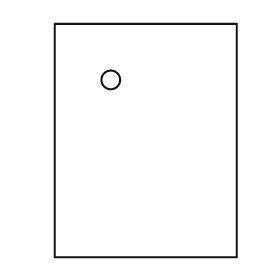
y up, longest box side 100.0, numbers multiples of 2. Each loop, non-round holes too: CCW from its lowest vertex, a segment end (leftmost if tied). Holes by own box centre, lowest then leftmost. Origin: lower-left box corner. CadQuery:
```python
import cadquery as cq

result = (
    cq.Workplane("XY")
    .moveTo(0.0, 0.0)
    .lineTo(78.0, 0.0)
    .lineTo(78.0, 100.0)
    .lineTo(0.0, 100.0)
    .close()
    .moveTo(24.0, 76.0)
    .circle(4.0)
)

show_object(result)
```